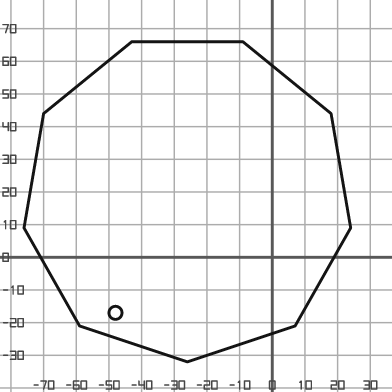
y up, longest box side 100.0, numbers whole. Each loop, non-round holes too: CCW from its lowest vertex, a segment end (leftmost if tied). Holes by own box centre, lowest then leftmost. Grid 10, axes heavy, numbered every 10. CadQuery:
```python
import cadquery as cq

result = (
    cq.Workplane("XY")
    .moveTo(-26.0, -32.0)
    .lineTo(7.0, -21.0)
    .lineTo(24.0, 9.0)
    .lineTo(18.0, 44.0)
    .lineTo(-9.0, 66.0)
    .lineTo(-43.0, 66.0)
    .lineTo(-70.0, 44.0)
    .lineTo(-76.0, 9.0)
    .lineTo(-59.0, -21.0)
    .close()
    .moveTo(-48.0, -17.0)
    .circle(2.0)
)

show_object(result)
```